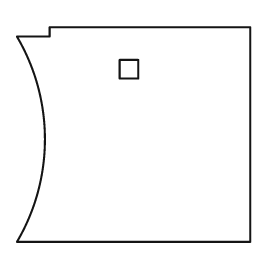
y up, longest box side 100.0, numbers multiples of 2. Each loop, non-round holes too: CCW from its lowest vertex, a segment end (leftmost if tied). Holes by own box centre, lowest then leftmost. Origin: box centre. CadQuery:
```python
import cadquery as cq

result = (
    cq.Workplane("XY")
    .moveTo(-50.0, -46.0)
    .lineTo(50.0, -46.0)
    .lineTo(50.0, 46.0)
    .lineTo(-36.0, 46.0)
    .lineTo(-36.0, 42.0)
    .lineTo(-50.0, 42.0)
    .threePointArc((-38.0, -2.0), (-50.0, -46.0))
    .close()
    .moveTo(-6.0, 24.0)
    .lineTo(2.0, 24.0)
    .lineTo(2.0, 32.0)
    .lineTo(-6.0, 32.0)
    .close()
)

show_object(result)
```